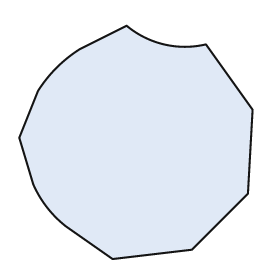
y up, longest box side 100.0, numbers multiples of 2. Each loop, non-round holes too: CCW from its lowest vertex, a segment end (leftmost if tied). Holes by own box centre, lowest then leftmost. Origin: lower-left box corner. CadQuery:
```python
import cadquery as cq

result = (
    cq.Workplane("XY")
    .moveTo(40.0, 0.0)
    .lineTo(74.0, 4.0)
    .lineTo(98.0, 28.0)
    .lineTo(100.0, 64.0)
    .lineTo(80.0, 92.0)
    .threePointArc((62.0, 92.0), (46.0, 100.0))
    .lineTo(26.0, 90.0)
    .threePointArc((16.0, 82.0), (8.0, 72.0))
    .lineTo(0.0, 52.0)
    .lineTo(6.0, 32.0)
    .threePointArc((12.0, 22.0), (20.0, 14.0))
    .close()
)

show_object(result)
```